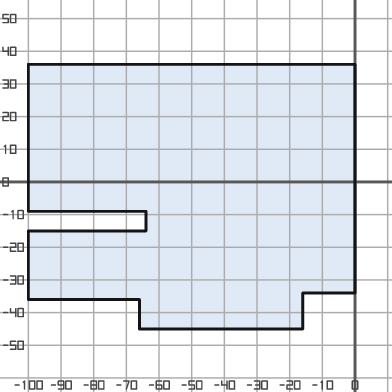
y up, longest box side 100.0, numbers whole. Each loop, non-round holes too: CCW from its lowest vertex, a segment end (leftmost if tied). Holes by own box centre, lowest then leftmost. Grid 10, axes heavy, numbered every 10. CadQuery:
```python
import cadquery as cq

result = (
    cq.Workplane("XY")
    .moveTo(-66.0, -45.0)
    .lineTo(-16.0, -45.0)
    .lineTo(-16.0, -34.0)
    .lineTo(0.0, -34.0)
    .lineTo(0.0, 36.0)
    .lineTo(-100.0, 36.0)
    .lineTo(-100.0, -9.0)
    .lineTo(-64.0, -9.0)
    .lineTo(-64.0, -15.0)
    .lineTo(-100.0, -15.0)
    .lineTo(-100.0, -36.0)
    .lineTo(-66.0, -36.0)
    .close()
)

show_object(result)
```